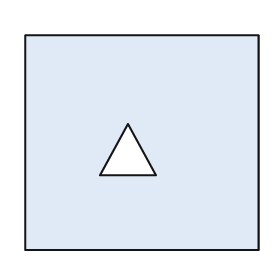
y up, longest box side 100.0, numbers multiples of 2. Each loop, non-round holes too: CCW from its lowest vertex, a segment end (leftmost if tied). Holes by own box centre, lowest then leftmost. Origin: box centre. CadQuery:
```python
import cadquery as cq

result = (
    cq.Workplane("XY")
    .moveTo(-50.0, -46.0)
    .lineTo(50.0, -46.0)
    .lineTo(50.0, 46.0)
    .lineTo(-50.0, 46.0)
    .close()
    .moveTo(-18.0, -14.0)
    .lineTo(6.0, -14.0)
    .lineTo(-6.0, 8.0)
    .close()
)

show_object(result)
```